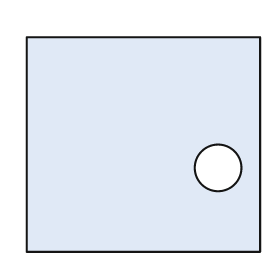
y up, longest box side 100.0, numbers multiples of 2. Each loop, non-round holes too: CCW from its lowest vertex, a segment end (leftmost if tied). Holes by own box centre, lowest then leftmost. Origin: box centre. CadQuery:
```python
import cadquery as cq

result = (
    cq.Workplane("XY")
    .moveTo(-50.0, -46.0)
    .lineTo(50.0, -46.0)
    .lineTo(50.0, 46.0)
    .lineTo(-50.0, 46.0)
    .close()
    .moveTo(32.0, -10.0)
    .circle(10.0)
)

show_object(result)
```